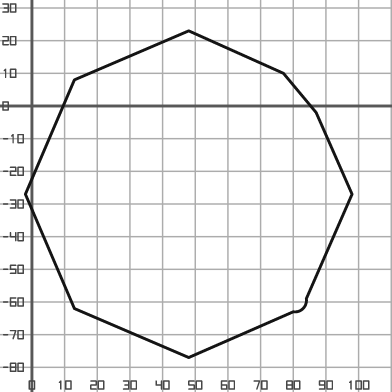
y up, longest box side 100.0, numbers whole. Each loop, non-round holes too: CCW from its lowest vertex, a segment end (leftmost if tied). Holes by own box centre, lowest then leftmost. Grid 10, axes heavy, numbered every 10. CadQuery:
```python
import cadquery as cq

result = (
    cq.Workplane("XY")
    .moveTo(48.0, -77.0)
    .lineTo(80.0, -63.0)
    .threePointArc((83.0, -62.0), (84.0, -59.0))
    .lineTo(98.0, -27.0)
    .lineTo(87.0, -2.0)
    .lineTo(77.0, 10.0)
    .lineTo(48.0, 23.0)
    .lineTo(13.0, 8.0)
    .lineTo(-2.0, -27.0)
    .lineTo(13.0, -62.0)
    .close()
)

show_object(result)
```